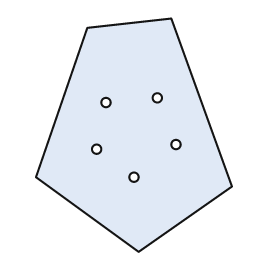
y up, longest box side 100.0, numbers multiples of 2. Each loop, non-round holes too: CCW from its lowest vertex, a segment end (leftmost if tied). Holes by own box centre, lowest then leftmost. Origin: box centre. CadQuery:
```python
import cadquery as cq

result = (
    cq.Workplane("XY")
    .moveTo(2.0, -50.0)
    .lineTo(42.0, -22.0)
    .lineTo(16.0, 50.0)
    .lineTo(-20.0, 46.0)
    .lineTo(-42.0, -18.0)
    .close()
    .moveTo(0.0, -18.0)
    .circle(2.0)
    .moveTo(-16.0, -6.0)
    .circle(2.0)
    .moveTo(18.0, -4.0)
    .circle(2.0)
    .moveTo(-12.0, 14.0)
    .circle(2.0)
    .moveTo(10.0, 16.0)
    .circle(2.0)
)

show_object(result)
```